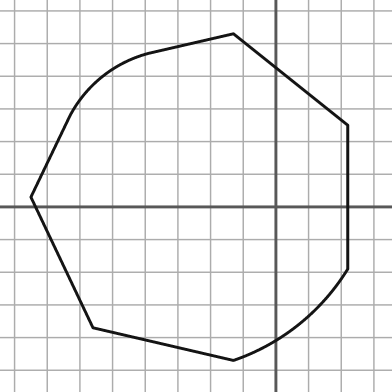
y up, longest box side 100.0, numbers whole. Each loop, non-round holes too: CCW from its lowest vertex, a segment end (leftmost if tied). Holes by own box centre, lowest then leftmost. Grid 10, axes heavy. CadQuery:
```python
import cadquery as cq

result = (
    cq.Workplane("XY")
    .moveTo(-13.0, -47.0)
    .threePointArc((7.0, -36.0), (22.0, -19.0))
    .lineTo(22.0, 25.0)
    .lineTo(-13.0, 53.0)
    .lineTo(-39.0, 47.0)
    .threePointArc((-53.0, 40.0), (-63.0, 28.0))
    .lineTo(-75.0, 3.0)
    .lineTo(-56.0, -37.0)
    .close()
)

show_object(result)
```